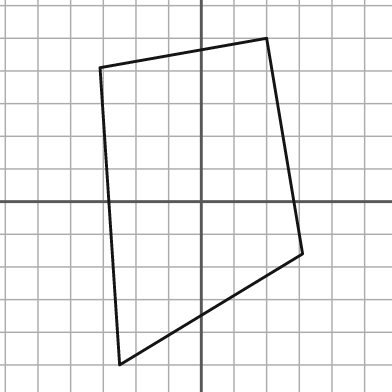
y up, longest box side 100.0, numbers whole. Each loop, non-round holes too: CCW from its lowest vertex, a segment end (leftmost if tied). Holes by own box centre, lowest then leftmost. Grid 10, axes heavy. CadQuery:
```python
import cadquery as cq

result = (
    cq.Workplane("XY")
    .moveTo(-25.0, -50.0)
    .lineTo(31.0, -16.0)
    .lineTo(20.0, 50.0)
    .lineTo(-31.0, 41.0)
    .close()
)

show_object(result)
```